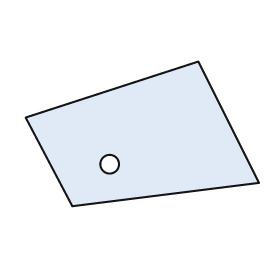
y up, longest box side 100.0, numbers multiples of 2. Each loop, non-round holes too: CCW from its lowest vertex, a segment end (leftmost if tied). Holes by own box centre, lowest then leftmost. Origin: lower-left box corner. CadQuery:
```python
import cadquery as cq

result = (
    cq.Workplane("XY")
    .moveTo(20.0, 0.0)
    .lineTo(100.0, 10.0)
    .lineTo(74.0, 62.0)
    .lineTo(0.0, 38.0)
    .close()
    .moveTo(36.0, 18.0)
    .circle(4.0)
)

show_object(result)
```